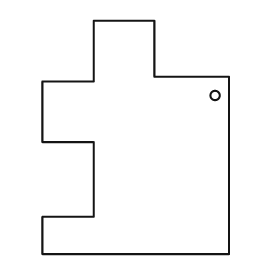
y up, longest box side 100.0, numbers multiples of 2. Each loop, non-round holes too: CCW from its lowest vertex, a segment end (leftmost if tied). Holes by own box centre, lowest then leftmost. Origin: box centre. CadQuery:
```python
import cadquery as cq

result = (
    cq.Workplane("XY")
    .moveTo(-40.0, -50.0)
    .lineTo(40.0, -50.0)
    .lineTo(40.0, 26.0)
    .lineTo(8.0, 26.0)
    .lineTo(8.0, 50.0)
    .lineTo(-18.0, 50.0)
    .lineTo(-18.0, 24.0)
    .lineTo(-40.0, 24.0)
    .lineTo(-40.0, -2.0)
    .lineTo(-18.0, -2.0)
    .lineTo(-18.0, -34.0)
    .lineTo(-40.0, -34.0)
    .close()
    .moveTo(34.0, 18.0)
    .circle(2.0)
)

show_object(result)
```